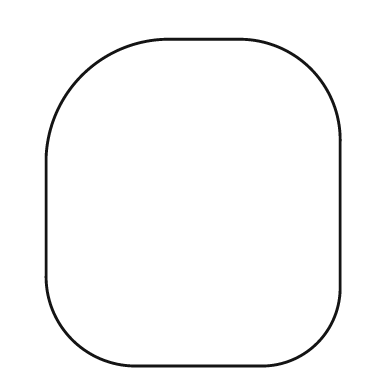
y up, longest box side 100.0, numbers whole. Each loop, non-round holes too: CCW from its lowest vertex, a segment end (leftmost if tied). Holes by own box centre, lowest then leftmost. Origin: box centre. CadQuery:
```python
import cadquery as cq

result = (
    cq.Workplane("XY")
    .moveTo(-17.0, -50.0)
    .lineTo(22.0, -50.0)
    .threePointArc((38.0, -43.0), (45.0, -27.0))
    .lineTo(45.0, 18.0)
    .threePointArc((36.0, 41.0), (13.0, 50.0))
    .lineTo(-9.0, 50.0)
    .threePointArc((-34.0, 39.0), (-45.0, 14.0))
    .lineTo(-45.0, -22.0)
    .threePointArc((-37.0, -42.0), (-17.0, -50.0))
    .close()
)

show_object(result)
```